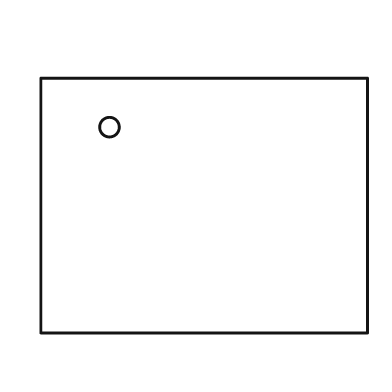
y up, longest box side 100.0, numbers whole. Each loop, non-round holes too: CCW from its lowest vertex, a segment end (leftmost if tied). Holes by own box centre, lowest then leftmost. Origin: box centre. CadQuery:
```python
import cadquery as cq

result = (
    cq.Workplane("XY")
    .moveTo(-50.0, -39.0)
    .lineTo(50.0, -39.0)
    .lineTo(50.0, 39.0)
    .lineTo(-50.0, 39.0)
    .close()
    .moveTo(-29.0, 24.0)
    .circle(3.0)
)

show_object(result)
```